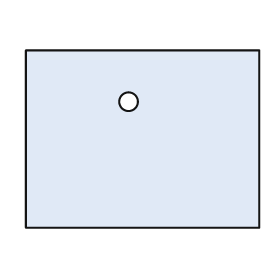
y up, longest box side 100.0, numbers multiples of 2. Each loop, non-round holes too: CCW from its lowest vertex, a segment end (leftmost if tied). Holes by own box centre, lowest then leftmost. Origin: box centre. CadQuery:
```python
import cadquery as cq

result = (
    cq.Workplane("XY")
    .moveTo(-50.0, -38.0)
    .lineTo(50.0, -38.0)
    .lineTo(50.0, 38.0)
    .lineTo(-50.0, 38.0)
    .close()
    .moveTo(-6.0, 16.0)
    .circle(4.0)
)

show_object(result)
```